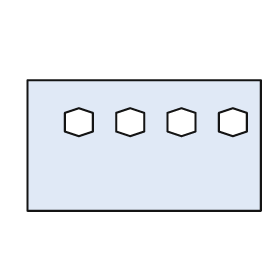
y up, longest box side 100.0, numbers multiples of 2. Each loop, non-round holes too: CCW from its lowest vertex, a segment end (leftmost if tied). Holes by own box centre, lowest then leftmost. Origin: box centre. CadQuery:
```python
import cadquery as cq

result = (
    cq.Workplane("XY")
    .moveTo(-50.0, -28.0)
    .lineTo(50.0, -28.0)
    .lineTo(50.0, 28.0)
    .lineTo(-50.0, 28.0)
    .close()
    .moveTo(-28.0, 4.0)
    .lineTo(-22.0, 6.0)
    .lineTo(-22.0, 14.0)
    .lineTo(-28.0, 16.0)
    .lineTo(-34.0, 14.0)
    .lineTo(-34.0, 6.0)
    .close()
    .moveTo(-6.0, 4.0)
    .lineTo(0.0, 6.0)
    .lineTo(0.0, 14.0)
    .lineTo(-6.0, 16.0)
    .lineTo(-12.0, 14.0)
    .lineTo(-12.0, 6.0)
    .close()
    .moveTo(16.0, 4.0)
    .lineTo(22.0, 6.0)
    .lineTo(22.0, 14.0)
    .lineTo(16.0, 16.0)
    .lineTo(10.0, 14.0)
    .lineTo(10.0, 6.0)
    .close()
    .moveTo(38.0, 4.0)
    .lineTo(44.0, 6.0)
    .lineTo(44.0, 14.0)
    .lineTo(38.0, 16.0)
    .lineTo(32.0, 14.0)
    .lineTo(32.0, 6.0)
    .close()
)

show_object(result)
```